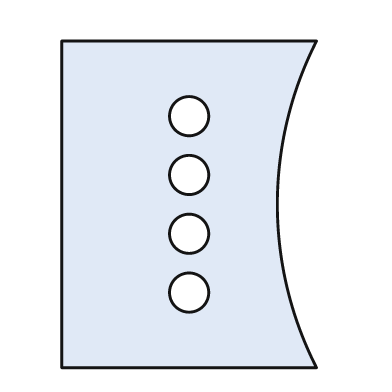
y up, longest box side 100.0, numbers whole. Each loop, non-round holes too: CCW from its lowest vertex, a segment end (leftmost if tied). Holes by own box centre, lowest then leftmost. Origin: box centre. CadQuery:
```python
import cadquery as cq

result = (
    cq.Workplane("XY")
    .moveTo(-39.0, -50.0)
    .lineTo(39.0, -50.0)
    .threePointArc((27.0, 0.0), (39.0, 50.0))
    .lineTo(-39.0, 50.0)
    .close()
    .moveTo(0.0, -27.0)
    .circle(6.0)
    .moveTo(0.0, -9.0)
    .circle(6.0)
    .moveTo(0.0, 9.0)
    .circle(6.0)
    .moveTo(0.0, 27.0)
    .circle(6.0)
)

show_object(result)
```